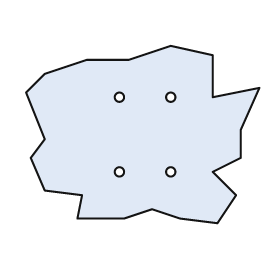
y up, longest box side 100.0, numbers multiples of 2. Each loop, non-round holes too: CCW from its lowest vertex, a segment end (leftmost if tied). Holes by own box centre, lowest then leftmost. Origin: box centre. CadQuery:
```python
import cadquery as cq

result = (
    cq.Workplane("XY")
    .moveTo(32.0, -38.0)
    .lineTo(40.0, -26.0)
    .lineTo(30.0, -16.0)
    .lineTo(42.0, -10.0)
    .lineTo(42.0, 2.0)
    .lineTo(50.0, 20.0)
    .lineTo(30.0, 16.0)
    .lineTo(30.0, 34.0)
    .lineTo(12.0, 38.0)
    .lineTo(-6.0, 32.0)
    .lineTo(-24.0, 32.0)
    .lineTo(-42.0, 26.0)
    .lineTo(-50.0, 18.0)
    .lineTo(-42.0, -2.0)
    .lineTo(-48.0, -10.0)
    .lineTo(-42.0, -24.0)
    .lineTo(-26.0, -26.0)
    .lineTo(-28.0, -36.0)
    .lineTo(-8.0, -36.0)
    .lineTo(4.0, -32.0)
    .lineTo(16.0, -36.0)
    .close()
    .moveTo(-10.0, -16.0)
    .circle(2.0)
    .moveTo(12.0, -16.0)
    .circle(2.0)
    .moveTo(-10.0, 16.0)
    .circle(2.0)
    .moveTo(12.0, 16.0)
    .circle(2.0)
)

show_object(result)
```